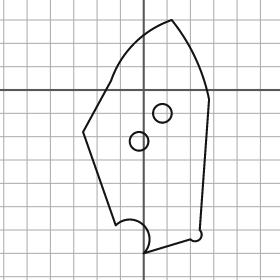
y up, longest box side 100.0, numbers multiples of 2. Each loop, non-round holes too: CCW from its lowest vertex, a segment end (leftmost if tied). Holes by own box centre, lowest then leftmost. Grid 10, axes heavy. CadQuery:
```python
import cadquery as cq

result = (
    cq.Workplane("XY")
    .moveTo(0.0, -70.0)
    .lineTo(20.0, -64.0)
    .threePointArc((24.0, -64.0), (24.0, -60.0))
    .lineTo(28.0, -4.0)
    .threePointArc((22.0, 14.0), (12.0, 30.0))
    .threePointArc((-4.0, 20.0), (-14.0, 4.0))
    .lineTo(-26.0, -18.0)
    .lineTo(-12.0, -58.0)
    .threePointArc((0.0, -58.0), (0.0, -70.0))
    .close()
    .moveTo(-2.0, -22.0)
    .circle(4.0)
    .moveTo(8.0, -10.0)
    .circle(4.0)
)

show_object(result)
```